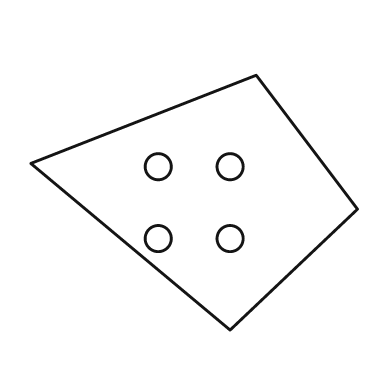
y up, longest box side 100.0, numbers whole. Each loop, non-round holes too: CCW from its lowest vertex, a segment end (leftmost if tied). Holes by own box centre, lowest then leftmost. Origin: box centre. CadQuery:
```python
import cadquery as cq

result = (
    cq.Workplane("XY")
    .moveTo(11.0, -39.0)
    .lineTo(50.0, -2.0)
    .lineTo(19.0, 39.0)
    .lineTo(-50.0, 12.0)
    .close()
    .moveTo(-11.0, -11.0)
    .circle(4.0)
    .moveTo(11.0, -11.0)
    .circle(4.0)
    .moveTo(-11.0, 11.0)
    .circle(4.0)
    .moveTo(11.0, 11.0)
    .circle(4.0)
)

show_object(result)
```